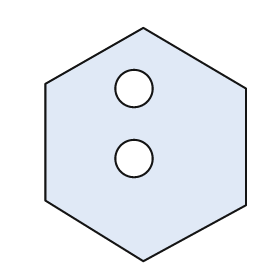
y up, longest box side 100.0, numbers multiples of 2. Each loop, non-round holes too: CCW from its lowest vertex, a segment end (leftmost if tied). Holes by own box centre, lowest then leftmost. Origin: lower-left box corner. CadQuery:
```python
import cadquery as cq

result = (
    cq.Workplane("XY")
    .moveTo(42.0, 0.0)
    .lineTo(86.0, 24.0)
    .lineTo(86.0, 74.0)
    .lineTo(42.0, 100.0)
    .lineTo(0.0, 76.0)
    .lineTo(0.0, 26.0)
    .close()
    .moveTo(38.0, 44.0)
    .circle(8.0)
    .moveTo(38.0, 74.0)
    .circle(8.0)
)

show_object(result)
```